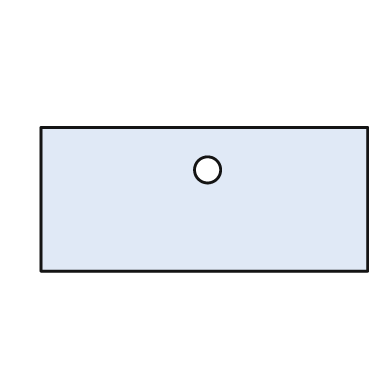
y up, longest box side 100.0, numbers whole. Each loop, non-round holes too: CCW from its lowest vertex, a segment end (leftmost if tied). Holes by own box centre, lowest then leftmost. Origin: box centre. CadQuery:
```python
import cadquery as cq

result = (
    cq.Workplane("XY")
    .moveTo(-50.0, -22.0)
    .lineTo(50.0, -22.0)
    .lineTo(50.0, 22.0)
    .lineTo(-50.0, 22.0)
    .close()
    .moveTo(1.0, 9.0)
    .circle(4.0)
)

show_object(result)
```